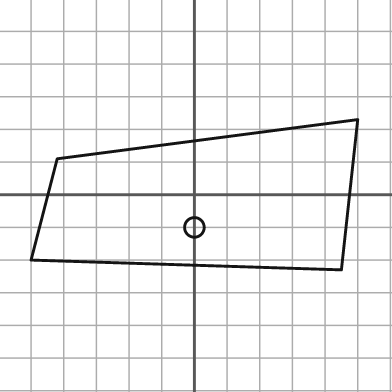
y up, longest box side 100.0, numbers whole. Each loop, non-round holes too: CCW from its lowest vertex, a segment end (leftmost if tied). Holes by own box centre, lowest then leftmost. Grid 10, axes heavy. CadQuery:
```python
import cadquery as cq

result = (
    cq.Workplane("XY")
    .moveTo(45.0, -23.0)
    .lineTo(50.0, 23.0)
    .lineTo(-42.0, 11.0)
    .lineTo(-50.0, -20.0)
    .close()
    .moveTo(0.0, -10.0)
    .circle(3.0)
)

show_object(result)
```